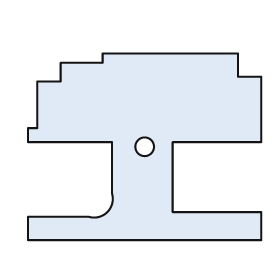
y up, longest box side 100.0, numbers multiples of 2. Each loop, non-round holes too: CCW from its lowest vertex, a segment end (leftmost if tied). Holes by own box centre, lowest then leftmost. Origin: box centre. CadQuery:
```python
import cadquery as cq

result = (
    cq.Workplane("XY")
    .moveTo(-50.0, -40.0)
    .lineTo(50.0, -40.0)
    .lineTo(50.0, -28.0)
    .lineTo(12.0, -28.0)
    .lineTo(12.0, 2.0)
    .lineTo(50.0, 2.0)
    .lineTo(50.0, 30.0)
    .lineTo(40.0, 30.0)
    .lineTo(40.0, 40.0)
    .lineTo(-18.0, 40.0)
    .lineTo(-18.0, 36.0)
    .lineTo(-36.0, 36.0)
    .lineTo(-36.0, 28.0)
    .lineTo(-46.0, 28.0)
    .lineTo(-46.0, 8.0)
    .lineTo(-50.0, 8.0)
    .lineTo(-50.0, 2.0)
    .lineTo(-14.0, 2.0)
    .lineTo(-14.0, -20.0)
    .threePointArc((-16.0, -28.0), (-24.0, -30.0))
    .lineTo(-50.0, -30.0)
    .close()
    .moveTo(0.0, 0.0)
    .circle(4.0)
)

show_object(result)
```